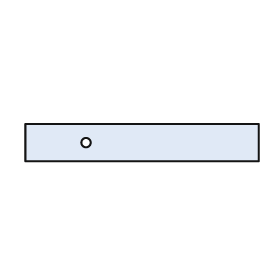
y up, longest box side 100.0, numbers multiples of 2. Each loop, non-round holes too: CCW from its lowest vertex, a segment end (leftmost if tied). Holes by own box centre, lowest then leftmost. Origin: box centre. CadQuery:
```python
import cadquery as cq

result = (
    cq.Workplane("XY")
    .moveTo(-50.0, -8.0)
    .lineTo(50.0, -8.0)
    .lineTo(50.0, 8.0)
    .lineTo(-50.0, 8.0)
    .close()
    .moveTo(-24.0, 0.0)
    .circle(2.0)
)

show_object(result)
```